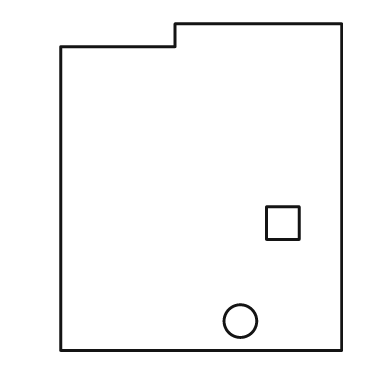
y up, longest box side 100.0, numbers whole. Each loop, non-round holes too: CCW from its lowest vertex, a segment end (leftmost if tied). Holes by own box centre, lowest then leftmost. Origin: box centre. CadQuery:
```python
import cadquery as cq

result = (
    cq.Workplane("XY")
    .moveTo(-43.0, -50.0)
    .lineTo(43.0, -50.0)
    .lineTo(43.0, 50.0)
    .lineTo(-8.0, 50.0)
    .lineTo(-8.0, 43.0)
    .lineTo(-43.0, 43.0)
    .close()
    .moveTo(12.0, -41.0)
    .circle(5.0)
    .moveTo(20.0, -16.0)
    .lineTo(30.0, -16.0)
    .lineTo(30.0, -6.0)
    .lineTo(20.0, -6.0)
    .close()
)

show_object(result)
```